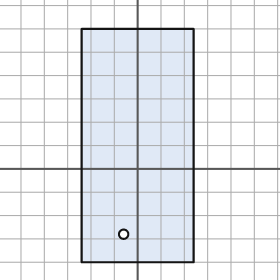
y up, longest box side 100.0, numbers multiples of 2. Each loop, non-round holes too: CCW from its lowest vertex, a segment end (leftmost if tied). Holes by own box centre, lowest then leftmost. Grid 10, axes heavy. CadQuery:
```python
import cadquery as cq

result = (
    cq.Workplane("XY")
    .moveTo(-24.0, -40.0)
    .lineTo(24.0, -40.0)
    .lineTo(24.0, 60.0)
    .lineTo(-24.0, 60.0)
    .close()
    .moveTo(-6.0, -28.0)
    .circle(2.0)
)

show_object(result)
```